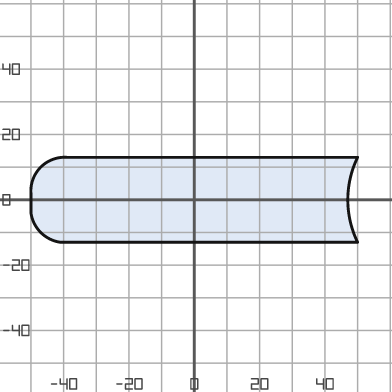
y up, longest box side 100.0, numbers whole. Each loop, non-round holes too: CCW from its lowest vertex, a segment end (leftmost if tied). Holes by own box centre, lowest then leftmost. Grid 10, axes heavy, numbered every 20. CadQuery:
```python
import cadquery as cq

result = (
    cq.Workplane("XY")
    .moveTo(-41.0, -13.0)
    .lineTo(50.0, -13.0)
    .threePointArc((47.0, 0.0), (50.0, 13.0))
    .lineTo(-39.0, 13.0)
    .threePointArc((-47.0, 10.0), (-50.0, 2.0))
    .lineTo(-50.0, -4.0)
    .threePointArc((-47.0, -10.0), (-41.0, -13.0))
    .close()
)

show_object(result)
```